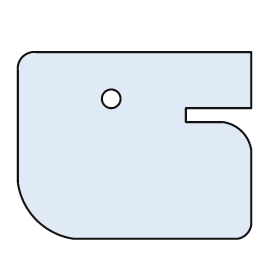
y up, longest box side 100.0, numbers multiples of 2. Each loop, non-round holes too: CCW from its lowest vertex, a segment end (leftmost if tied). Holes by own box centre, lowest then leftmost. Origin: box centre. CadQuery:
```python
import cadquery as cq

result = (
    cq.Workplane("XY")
    .moveTo(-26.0, -40.0)
    .lineTo(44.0, -40.0)
    .threePointArc((48.0, -38.0), (50.0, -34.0))
    .lineTo(50.0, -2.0)
    .threePointArc((46.0, 6.0), (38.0, 10.0))
    .lineTo(22.0, 10.0)
    .lineTo(22.0, 16.0)
    .lineTo(50.0, 16.0)
    .lineTo(50.0, 40.0)
    .lineTo(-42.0, 40.0)
    .threePointArc((-48.0, 38.0), (-50.0, 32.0))
    .lineTo(-50.0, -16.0)
    .threePointArc((-42.0, -32.0), (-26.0, -40.0))
    .close()
    .moveTo(-10.0, 20.0)
    .circle(4.0)
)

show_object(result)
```